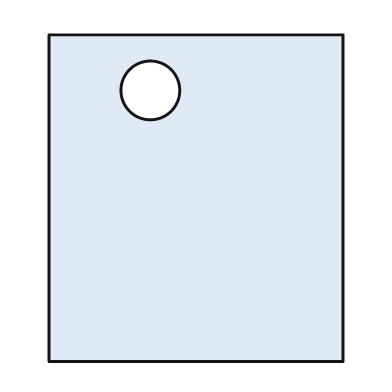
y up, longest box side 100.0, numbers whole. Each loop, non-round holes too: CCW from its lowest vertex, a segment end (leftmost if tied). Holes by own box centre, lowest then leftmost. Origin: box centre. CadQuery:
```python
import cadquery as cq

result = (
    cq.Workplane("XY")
    .moveTo(-45.0, -50.0)
    .lineTo(45.0, -50.0)
    .lineTo(45.0, 50.0)
    .lineTo(-45.0, 50.0)
    .close()
    .moveTo(-14.0, 33.0)
    .circle(9.0)
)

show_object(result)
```